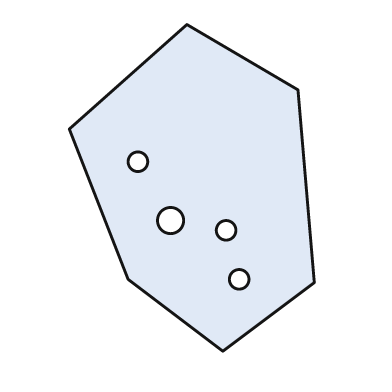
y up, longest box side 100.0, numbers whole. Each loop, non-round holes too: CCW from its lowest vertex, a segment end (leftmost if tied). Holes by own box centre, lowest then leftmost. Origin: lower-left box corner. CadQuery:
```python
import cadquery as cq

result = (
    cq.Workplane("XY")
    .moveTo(47.0, 0.0)
    .lineTo(75.0, 21.0)
    .lineTo(70.0, 80.0)
    .lineTo(36.0, 100.0)
    .lineTo(0.0, 68.0)
    .lineTo(18.0, 22.0)
    .close()
    .moveTo(52.0, 22.0)
    .circle(3.0)
    .moveTo(48.0, 37.0)
    .circle(3.0)
    .moveTo(31.0, 40.0)
    .circle(4.0)
    .moveTo(21.0, 58.0)
    .circle(3.0)
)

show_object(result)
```